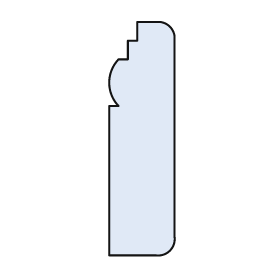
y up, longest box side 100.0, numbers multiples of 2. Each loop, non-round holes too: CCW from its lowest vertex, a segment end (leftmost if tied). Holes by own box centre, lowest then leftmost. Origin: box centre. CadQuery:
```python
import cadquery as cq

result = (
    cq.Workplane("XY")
    .moveTo(-14.0, -50.0)
    .lineTo(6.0, -50.0)
    .threePointArc((12.0, -48.0), (14.0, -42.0))
    .lineTo(14.0, 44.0)
    .threePointArc((12.0, 48.0), (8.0, 50.0))
    .lineTo(-2.0, 50.0)
    .lineTo(-2.0, 42.0)
    .lineTo(-6.0, 42.0)
    .lineTo(-6.0, 34.0)
    .lineTo(-10.0, 34.0)
    .threePointArc((-14.0, 24.0), (-10.0, 14.0))
    .lineTo(-14.0, 14.0)
    .close()
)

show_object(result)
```